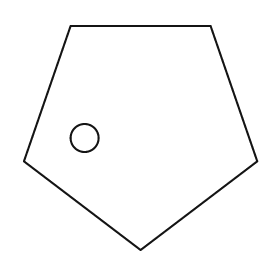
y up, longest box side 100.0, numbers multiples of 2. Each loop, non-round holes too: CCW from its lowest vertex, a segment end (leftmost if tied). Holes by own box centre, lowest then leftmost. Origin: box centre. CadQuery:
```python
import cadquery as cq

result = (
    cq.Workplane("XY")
    .moveTo(0.0, -48.0)
    .lineTo(50.0, -10.0)
    .lineTo(30.0, 48.0)
    .lineTo(-30.0, 48.0)
    .lineTo(-50.0, -10.0)
    .close()
    .moveTo(-24.0, 0.0)
    .circle(6.0)
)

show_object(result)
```